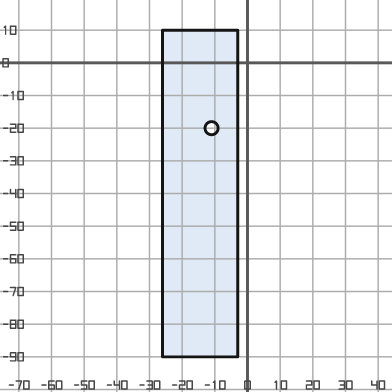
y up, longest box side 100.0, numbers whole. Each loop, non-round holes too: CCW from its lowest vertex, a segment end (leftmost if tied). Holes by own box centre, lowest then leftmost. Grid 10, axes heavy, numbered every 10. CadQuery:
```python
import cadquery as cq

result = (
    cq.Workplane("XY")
    .moveTo(-26.0, -90.0)
    .lineTo(-3.0, -90.0)
    .lineTo(-3.0, 10.0)
    .lineTo(-26.0, 10.0)
    .close()
    .moveTo(-11.0, -20.0)
    .circle(2.0)
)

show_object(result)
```